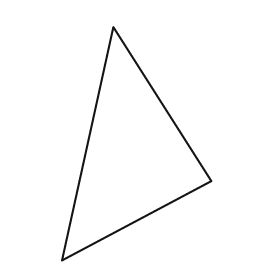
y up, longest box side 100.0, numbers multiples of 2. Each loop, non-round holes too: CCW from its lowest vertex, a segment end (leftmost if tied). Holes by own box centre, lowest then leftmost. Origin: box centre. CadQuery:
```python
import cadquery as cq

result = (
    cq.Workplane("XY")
    .moveTo(-32.0, -50.0)
    .lineTo(32.0, -16.0)
    .lineTo(-10.0, 50.0)
    .close()
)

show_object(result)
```